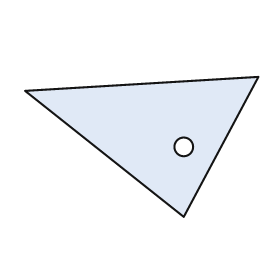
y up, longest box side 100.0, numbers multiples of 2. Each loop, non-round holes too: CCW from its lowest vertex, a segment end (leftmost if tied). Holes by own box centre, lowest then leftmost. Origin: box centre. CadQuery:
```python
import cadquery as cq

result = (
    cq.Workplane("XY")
    .moveTo(18.0, -30.0)
    .lineTo(50.0, 30.0)
    .lineTo(-50.0, 24.0)
    .close()
    .moveTo(18.0, 0.0)
    .circle(4.0)
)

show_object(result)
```